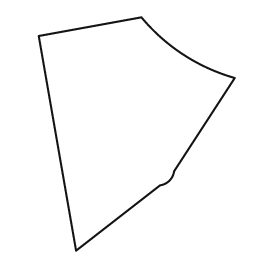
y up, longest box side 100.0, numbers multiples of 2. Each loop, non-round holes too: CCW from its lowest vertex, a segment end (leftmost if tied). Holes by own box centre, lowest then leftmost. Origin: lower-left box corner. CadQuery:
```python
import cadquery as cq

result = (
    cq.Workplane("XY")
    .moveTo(16.0, 0.0)
    .lineTo(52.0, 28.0)
    .threePointArc((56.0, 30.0), (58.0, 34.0))
    .lineTo(84.0, 74.0)
    .threePointArc((62.0, 84.0), (44.0, 100.0))
    .lineTo(0.0, 92.0)
    .close()
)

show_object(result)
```